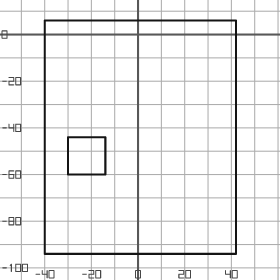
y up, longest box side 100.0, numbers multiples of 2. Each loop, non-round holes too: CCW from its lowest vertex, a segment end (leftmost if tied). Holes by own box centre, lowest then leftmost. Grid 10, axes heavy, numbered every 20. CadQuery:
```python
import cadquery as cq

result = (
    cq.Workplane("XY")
    .moveTo(-40.0, -94.0)
    .lineTo(42.0, -94.0)
    .lineTo(42.0, 6.0)
    .lineTo(-40.0, 6.0)
    .close()
    .moveTo(-30.0, -60.0)
    .lineTo(-14.0, -60.0)
    .lineTo(-14.0, -44.0)
    .lineTo(-30.0, -44.0)
    .close()
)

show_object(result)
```